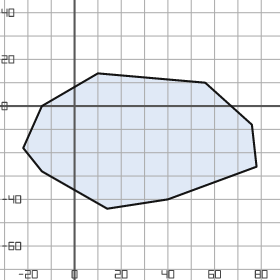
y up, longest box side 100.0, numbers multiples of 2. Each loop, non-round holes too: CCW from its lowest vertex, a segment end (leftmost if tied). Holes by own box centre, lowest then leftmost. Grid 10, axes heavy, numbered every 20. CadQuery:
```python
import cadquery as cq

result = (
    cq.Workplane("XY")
    .moveTo(14.0, -44.0)
    .lineTo(40.0, -40.0)
    .lineTo(78.0, -26.0)
    .lineTo(76.0, -8.0)
    .lineTo(56.0, 10.0)
    .lineTo(10.0, 14.0)
    .lineTo(-14.0, 0.0)
    .lineTo(-22.0, -18.0)
    .lineTo(-14.0, -28.0)
    .close()
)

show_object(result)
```